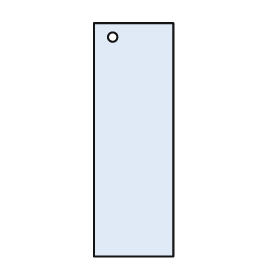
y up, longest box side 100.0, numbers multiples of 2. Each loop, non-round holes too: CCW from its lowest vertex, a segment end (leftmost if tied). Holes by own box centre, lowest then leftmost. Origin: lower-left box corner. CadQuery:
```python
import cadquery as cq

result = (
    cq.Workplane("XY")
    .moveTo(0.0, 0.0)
    .lineTo(34.0, 0.0)
    .lineTo(34.0, 100.0)
    .lineTo(0.0, 100.0)
    .close()
    .moveTo(8.0, 94.0)
    .circle(2.0)
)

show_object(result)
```